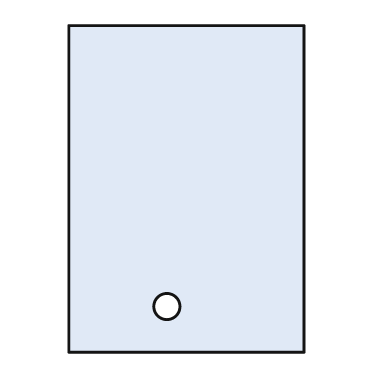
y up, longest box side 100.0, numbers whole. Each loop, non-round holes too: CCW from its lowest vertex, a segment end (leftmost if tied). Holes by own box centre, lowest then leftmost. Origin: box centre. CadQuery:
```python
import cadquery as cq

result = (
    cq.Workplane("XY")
    .moveTo(-36.0, -50.0)
    .lineTo(36.0, -50.0)
    .lineTo(36.0, 50.0)
    .lineTo(-36.0, 50.0)
    .close()
    .moveTo(-6.0, -36.0)
    .circle(4.0)
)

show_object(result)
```